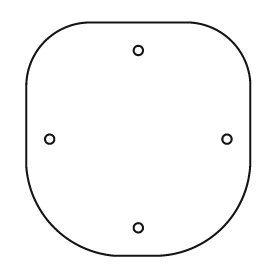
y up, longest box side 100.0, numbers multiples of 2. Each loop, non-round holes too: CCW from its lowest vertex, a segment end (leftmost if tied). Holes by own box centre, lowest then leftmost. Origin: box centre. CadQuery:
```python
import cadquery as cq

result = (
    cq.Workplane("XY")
    .moveTo(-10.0, -50.0)
    .lineTo(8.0, -50.0)
    .threePointArc((36.0, -38.0), (48.0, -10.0))
    .lineTo(48.0, 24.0)
    .threePointArc((40.0, 42.0), (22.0, 50.0))
    .lineTo(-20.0, 50.0)
    .threePointArc((-40.0, 42.0), (-48.0, 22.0))
    .lineTo(-48.0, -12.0)
    .threePointArc((-36.0, -38.0), (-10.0, -50.0))
    .close()
    .moveTo(0.0, -38.0)
    .circle(2.0)
    .moveTo(-38.0, 0.0)
    .circle(2.0)
    .moveTo(38.0, 0.0)
    .circle(2.0)
    .moveTo(0.0, 38.0)
    .circle(2.0)
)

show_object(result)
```